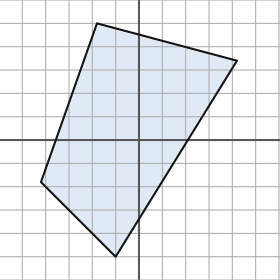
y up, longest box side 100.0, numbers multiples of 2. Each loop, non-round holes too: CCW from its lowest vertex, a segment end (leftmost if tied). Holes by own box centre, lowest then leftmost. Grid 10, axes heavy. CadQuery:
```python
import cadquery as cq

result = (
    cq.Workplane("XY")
    .moveTo(-10.0, -50.0)
    .lineTo(42.0, 34.0)
    .lineTo(-18.0, 50.0)
    .lineTo(-42.0, -18.0)
    .close()
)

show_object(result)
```